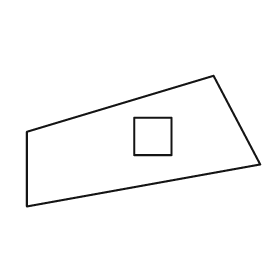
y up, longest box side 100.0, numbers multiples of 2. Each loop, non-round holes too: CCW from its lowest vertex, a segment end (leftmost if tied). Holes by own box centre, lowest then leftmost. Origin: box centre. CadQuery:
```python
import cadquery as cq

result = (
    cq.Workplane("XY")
    .moveTo(-50.0, -28.0)
    .lineTo(50.0, -10.0)
    .lineTo(30.0, 28.0)
    .lineTo(-50.0, 4.0)
    .close()
    .moveTo(-4.0, -6.0)
    .lineTo(12.0, -6.0)
    .lineTo(12.0, 10.0)
    .lineTo(-4.0, 10.0)
    .close()
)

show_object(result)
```